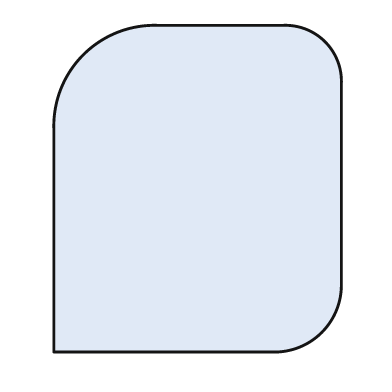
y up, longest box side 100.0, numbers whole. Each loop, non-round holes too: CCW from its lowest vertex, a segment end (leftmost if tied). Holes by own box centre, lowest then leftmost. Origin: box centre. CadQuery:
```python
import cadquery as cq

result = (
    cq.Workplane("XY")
    .moveTo(-44.0, -50.0)
    .lineTo(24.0, -50.0)
    .threePointArc((38.0, -44.0), (44.0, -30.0))
    .lineTo(44.0, 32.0)
    .threePointArc((39.0, 45.0), (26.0, 50.0))
    .lineTo(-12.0, 50.0)
    .threePointArc((-35.0, 41.0), (-44.0, 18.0))
    .close()
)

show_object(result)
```